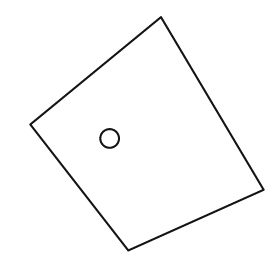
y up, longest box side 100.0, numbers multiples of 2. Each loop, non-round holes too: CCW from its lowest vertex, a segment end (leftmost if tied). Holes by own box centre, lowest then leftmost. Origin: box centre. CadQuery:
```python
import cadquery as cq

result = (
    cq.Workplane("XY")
    .moveTo(-8.0, -50.0)
    .lineTo(50.0, -24.0)
    .lineTo(6.0, 50.0)
    .lineTo(-50.0, 4.0)
    .close()
    .moveTo(-16.0, -2.0)
    .circle(4.0)
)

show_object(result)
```